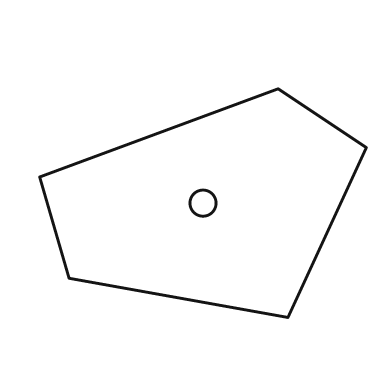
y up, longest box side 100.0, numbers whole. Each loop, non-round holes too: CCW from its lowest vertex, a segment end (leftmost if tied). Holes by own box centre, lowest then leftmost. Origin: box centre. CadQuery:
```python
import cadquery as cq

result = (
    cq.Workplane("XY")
    .moveTo(26.0, -35.0)
    .lineTo(50.0, 17.0)
    .lineTo(23.0, 35.0)
    .lineTo(-50.0, 8.0)
    .lineTo(-41.0, -23.0)
    .close()
    .moveTo(0.0, 0.0)
    .circle(4.0)
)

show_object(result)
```